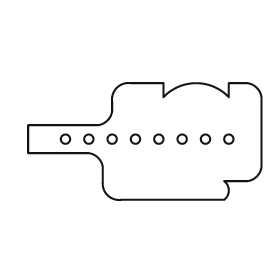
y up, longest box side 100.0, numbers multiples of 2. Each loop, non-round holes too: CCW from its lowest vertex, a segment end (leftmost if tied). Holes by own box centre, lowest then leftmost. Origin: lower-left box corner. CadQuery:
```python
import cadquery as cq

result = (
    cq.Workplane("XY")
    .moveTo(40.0, 0.0)
    .lineTo(84.0, 0.0)
    .threePointArc((86.0, 4.0), (84.0, 8.0))
    .lineTo(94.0, 8.0)
    .threePointArc((98.0, 10.0), (100.0, 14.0))
    .lineTo(100.0, 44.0)
    .threePointArc((98.0, 48.0), (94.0, 50.0))
    .lineTo(86.0, 50.0)
    .lineTo(86.0, 44.0)
    .threePointArc((72.0, 50.0), (58.0, 44.0))
    .lineTo(58.0, 50.0)
    .lineTo(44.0, 50.0)
    .threePointArc((38.0, 48.0), (36.0, 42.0))
    .lineTo(36.0, 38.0)
    .threePointArc((34.0, 34.0), (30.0, 32.0))
    .lineTo(0.0, 32.0)
    .lineTo(0.0, 20.0)
    .lineTo(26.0, 20.0)
    .threePointArc((30.0, 18.0), (32.0, 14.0))
    .lineTo(32.0, 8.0)
    .threePointArc((34.0, 2.0), (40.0, 0.0))
    .close()
    .moveTo(16.0, 26.0)
    .circle(2.0)
    .moveTo(26.0, 26.0)
    .circle(2.0)
    .moveTo(36.0, 26.0)
    .circle(2.0)
    .moveTo(46.0, 26.0)
    .circle(2.0)
    .moveTo(56.0, 26.0)
    .circle(2.0)
    .moveTo(66.0, 26.0)
    .circle(2.0)
    .moveTo(76.0, 26.0)
    .circle(2.0)
    .moveTo(86.0, 26.0)
    .circle(2.0)
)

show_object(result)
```